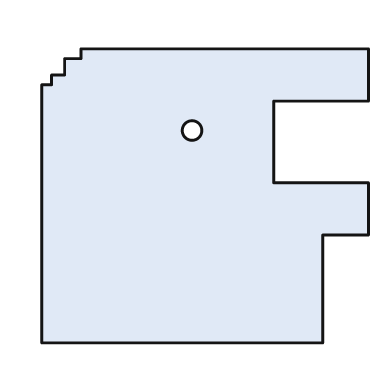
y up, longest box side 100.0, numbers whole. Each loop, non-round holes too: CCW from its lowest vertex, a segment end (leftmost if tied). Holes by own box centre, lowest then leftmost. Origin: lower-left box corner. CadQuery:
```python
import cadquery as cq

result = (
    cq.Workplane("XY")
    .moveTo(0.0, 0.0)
    .lineTo(86.0, 0.0)
    .lineTo(86.0, 33.0)
    .lineTo(100.0, 33.0)
    .lineTo(100.0, 49.0)
    .lineTo(71.0, 49.0)
    .lineTo(71.0, 74.0)
    .lineTo(100.0, 74.0)
    .lineTo(100.0, 90.0)
    .lineTo(12.0, 90.0)
    .lineTo(12.0, 87.0)
    .lineTo(7.0, 87.0)
    .lineTo(7.0, 82.0)
    .lineTo(3.0, 82.0)
    .lineTo(3.0, 79.0)
    .lineTo(0.0, 79.0)
    .close()
    .moveTo(46.0, 65.0)
    .circle(3.0)
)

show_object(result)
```